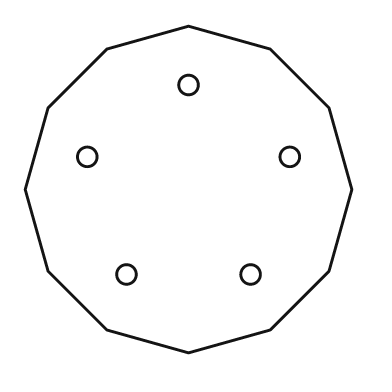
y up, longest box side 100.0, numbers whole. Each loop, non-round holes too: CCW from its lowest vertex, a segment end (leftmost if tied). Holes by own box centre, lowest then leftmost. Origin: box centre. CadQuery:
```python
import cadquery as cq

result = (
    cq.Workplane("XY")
    .moveTo(0.0, -50.0)
    .lineTo(25.0, -43.0)
    .lineTo(43.0, -25.0)
    .lineTo(50.0, 0.0)
    .lineTo(43.0, 25.0)
    .lineTo(25.0, 43.0)
    .lineTo(0.0, 50.0)
    .lineTo(-25.0, 43.0)
    .lineTo(-43.0, 25.0)
    .lineTo(-50.0, 0.0)
    .lineTo(-43.0, -25.0)
    .lineTo(-25.0, -43.0)
    .close()
    .moveTo(-19.0, -26.0)
    .circle(3.0)
    .moveTo(19.0, -26.0)
    .circle(3.0)
    .moveTo(-31.0, 10.0)
    .circle(3.0)
    .moveTo(31.0, 10.0)
    .circle(3.0)
    .moveTo(0.0, 32.0)
    .circle(3.0)
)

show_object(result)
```